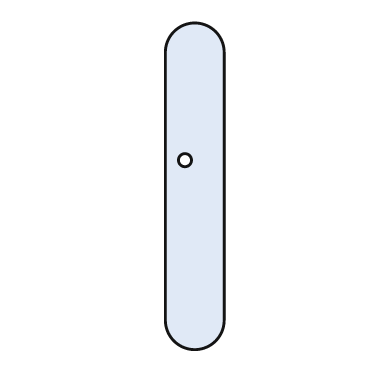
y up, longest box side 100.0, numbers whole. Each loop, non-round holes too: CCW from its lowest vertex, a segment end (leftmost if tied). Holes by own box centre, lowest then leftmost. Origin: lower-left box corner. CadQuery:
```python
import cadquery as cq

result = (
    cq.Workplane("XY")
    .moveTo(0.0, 9.0)
    .threePointArc((9.0, 0.0), (18.0, 9.0))
    .lineTo(18.0, 91.0)
    .threePointArc((9.0, 100.0), (0.0, 91.0))
    .close()
    .moveTo(6.0, 58.0)
    .circle(2.0)
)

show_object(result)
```